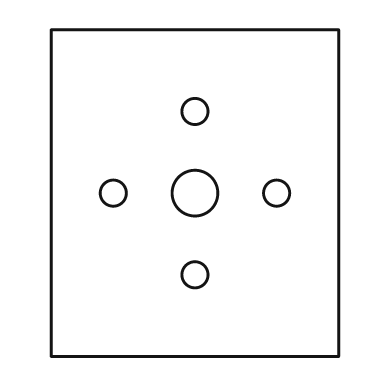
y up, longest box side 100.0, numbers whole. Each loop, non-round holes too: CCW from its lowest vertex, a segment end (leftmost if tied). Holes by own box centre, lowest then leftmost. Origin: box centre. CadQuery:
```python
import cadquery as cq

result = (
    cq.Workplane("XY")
    .moveTo(-44.0, -50.0)
    .lineTo(44.0, -50.0)
    .lineTo(44.0, 50.0)
    .lineTo(-44.0, 50.0)
    .close()
    .moveTo(0.0, -25.0)
    .circle(4.0)
    .moveTo(-25.0, 0.0)
    .circle(4.0)
    .moveTo(0.0, 0.0)
    .circle(7.0)
    .moveTo(25.0, 0.0)
    .circle(4.0)
    .moveTo(0.0, 25.0)
    .circle(4.0)
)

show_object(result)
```